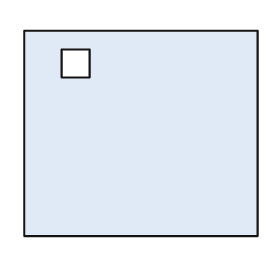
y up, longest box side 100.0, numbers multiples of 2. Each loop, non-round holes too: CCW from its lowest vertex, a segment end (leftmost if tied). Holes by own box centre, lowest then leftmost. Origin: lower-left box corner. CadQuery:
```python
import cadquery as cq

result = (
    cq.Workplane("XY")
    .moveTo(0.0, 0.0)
    .lineTo(100.0, 0.0)
    .lineTo(100.0, 88.0)
    .lineTo(0.0, 88.0)
    .close()
    .moveTo(16.0, 68.0)
    .lineTo(28.0, 68.0)
    .lineTo(28.0, 80.0)
    .lineTo(16.0, 80.0)
    .close()
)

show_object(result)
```